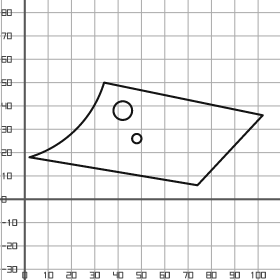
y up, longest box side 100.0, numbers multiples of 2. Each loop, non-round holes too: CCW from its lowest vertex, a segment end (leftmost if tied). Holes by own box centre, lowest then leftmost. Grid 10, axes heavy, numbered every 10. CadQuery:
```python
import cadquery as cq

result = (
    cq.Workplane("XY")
    .moveTo(74.0, 6.0)
    .lineTo(102.0, 36.0)
    .lineTo(34.0, 50.0)
    .threePointArc((22.0, 30.0), (2.0, 18.0))
    .close()
    .moveTo(48.0, 26.0)
    .circle(2.0)
    .moveTo(42.0, 38.0)
    .circle(4.0)
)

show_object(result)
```